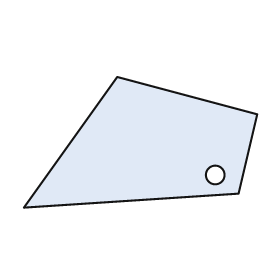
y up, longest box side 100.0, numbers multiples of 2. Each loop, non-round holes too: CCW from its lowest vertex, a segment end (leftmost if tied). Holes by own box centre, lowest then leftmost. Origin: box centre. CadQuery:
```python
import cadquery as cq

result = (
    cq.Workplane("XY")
    .moveTo(-50.0, -28.0)
    .lineTo(42.0, -22.0)
    .lineTo(50.0, 12.0)
    .lineTo(-10.0, 28.0)
    .close()
    .moveTo(32.0, -14.0)
    .circle(4.0)
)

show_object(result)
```